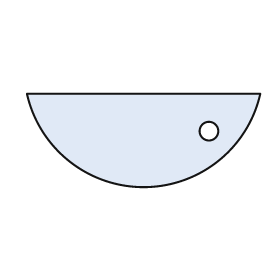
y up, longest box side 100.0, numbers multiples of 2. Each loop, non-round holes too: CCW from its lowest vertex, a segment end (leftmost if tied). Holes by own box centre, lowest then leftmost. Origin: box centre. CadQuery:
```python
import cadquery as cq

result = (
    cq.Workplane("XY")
    .moveTo(-50.0, 20.0)
    .threePointArc((0.0, -20.0), (50.0, 20.0))
    .close()
    .moveTo(28.0, 4.0)
    .circle(4.0)
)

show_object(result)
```